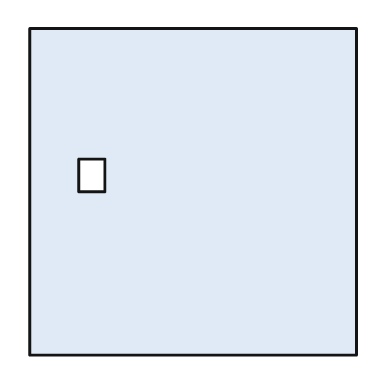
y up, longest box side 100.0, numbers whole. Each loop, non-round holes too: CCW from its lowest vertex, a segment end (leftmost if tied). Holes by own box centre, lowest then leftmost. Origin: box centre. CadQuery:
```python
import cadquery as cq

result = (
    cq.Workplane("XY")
    .moveTo(-50.0, -50.0)
    .lineTo(50.0, -50.0)
    .lineTo(50.0, 50.0)
    .lineTo(-50.0, 50.0)
    .close()
    .moveTo(-35.0, 0.0)
    .lineTo(-27.0, 0.0)
    .lineTo(-27.0, 10.0)
    .lineTo(-35.0, 10.0)
    .close()
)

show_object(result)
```